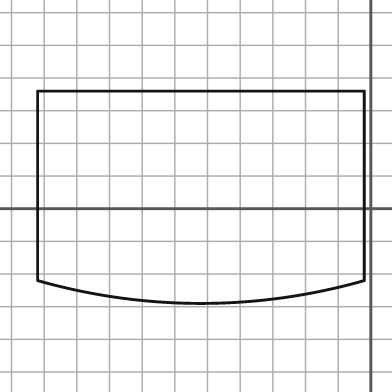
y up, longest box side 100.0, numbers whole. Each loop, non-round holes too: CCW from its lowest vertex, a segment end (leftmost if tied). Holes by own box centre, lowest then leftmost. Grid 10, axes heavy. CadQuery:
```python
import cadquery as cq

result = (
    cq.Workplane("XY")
    .moveTo(-102.0, -22.0)
    .threePointArc((-52.0, -29.0), (-2.0, -22.0))
    .lineTo(-2.0, 36.0)
    .lineTo(-102.0, 36.0)
    .close()
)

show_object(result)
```